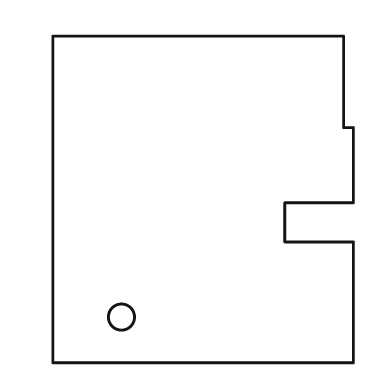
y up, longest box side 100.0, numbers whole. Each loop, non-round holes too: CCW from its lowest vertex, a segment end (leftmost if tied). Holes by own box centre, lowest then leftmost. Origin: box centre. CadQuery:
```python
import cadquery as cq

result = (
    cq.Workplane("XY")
    .moveTo(-46.0, -50.0)
    .lineTo(46.0, -50.0)
    .lineTo(46.0, -13.0)
    .lineTo(25.0, -13.0)
    .lineTo(25.0, -1.0)
    .lineTo(46.0, -1.0)
    .lineTo(46.0, 22.0)
    .lineTo(43.0, 22.0)
    .lineTo(43.0, 50.0)
    .lineTo(-46.0, 50.0)
    .close()
    .moveTo(-25.0, -36.0)
    .circle(4.0)
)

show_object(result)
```